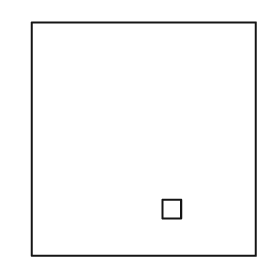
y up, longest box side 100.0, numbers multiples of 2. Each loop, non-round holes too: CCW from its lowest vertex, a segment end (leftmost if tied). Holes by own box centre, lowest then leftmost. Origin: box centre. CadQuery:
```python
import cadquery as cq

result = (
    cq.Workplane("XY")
    .moveTo(-48.0, -50.0)
    .lineTo(48.0, -50.0)
    .lineTo(48.0, 50.0)
    .lineTo(-48.0, 50.0)
    .close()
    .moveTo(8.0, -34.0)
    .lineTo(16.0, -34.0)
    .lineTo(16.0, -26.0)
    .lineTo(8.0, -26.0)
    .close()
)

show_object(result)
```